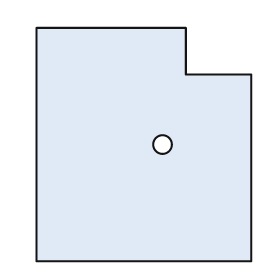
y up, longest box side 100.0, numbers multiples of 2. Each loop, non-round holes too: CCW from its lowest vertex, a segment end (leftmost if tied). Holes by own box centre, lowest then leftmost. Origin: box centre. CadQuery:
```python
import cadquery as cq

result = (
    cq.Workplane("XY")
    .moveTo(-46.0, -50.0)
    .lineTo(46.0, -50.0)
    .lineTo(46.0, 30.0)
    .lineTo(18.0, 30.0)
    .lineTo(18.0, 50.0)
    .lineTo(-46.0, 50.0)
    .close()
    .moveTo(8.0, 0.0)
    .circle(4.0)
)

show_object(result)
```